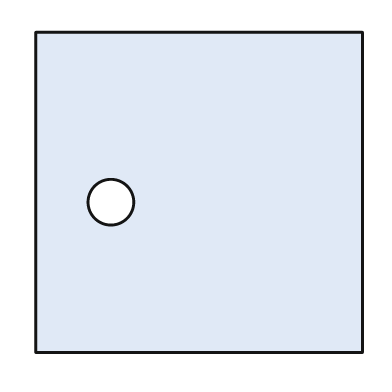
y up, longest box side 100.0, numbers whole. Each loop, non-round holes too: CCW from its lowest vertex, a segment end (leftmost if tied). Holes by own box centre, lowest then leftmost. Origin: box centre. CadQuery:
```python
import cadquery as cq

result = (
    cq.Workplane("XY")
    .moveTo(-50.0, -49.0)
    .lineTo(50.0, -49.0)
    .lineTo(50.0, 49.0)
    .lineTo(-50.0, 49.0)
    .close()
    .moveTo(-27.0, -3.0)
    .circle(7.0)
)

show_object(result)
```